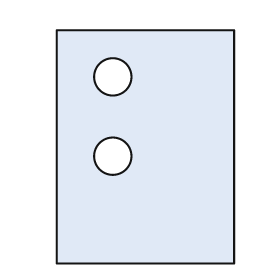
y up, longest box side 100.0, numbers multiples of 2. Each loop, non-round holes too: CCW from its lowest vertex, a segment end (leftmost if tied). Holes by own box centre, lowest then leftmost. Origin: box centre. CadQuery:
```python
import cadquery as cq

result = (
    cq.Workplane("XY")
    .moveTo(-38.0, -50.0)
    .lineTo(38.0, -50.0)
    .lineTo(38.0, 50.0)
    .lineTo(-38.0, 50.0)
    .close()
    .moveTo(-14.0, -4.0)
    .circle(8.0)
    .moveTo(-14.0, 30.0)
    .circle(8.0)
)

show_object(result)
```